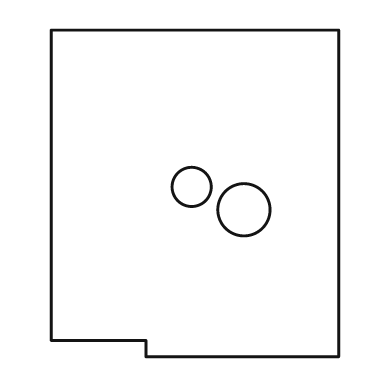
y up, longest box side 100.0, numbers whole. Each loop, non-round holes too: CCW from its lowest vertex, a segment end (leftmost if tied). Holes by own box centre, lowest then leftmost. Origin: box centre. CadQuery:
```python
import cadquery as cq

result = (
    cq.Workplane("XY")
    .moveTo(-15.0, -50.0)
    .lineTo(44.0, -50.0)
    .lineTo(44.0, 50.0)
    .lineTo(-44.0, 50.0)
    .lineTo(-44.0, -45.0)
    .lineTo(-15.0, -45.0)
    .close()
    .moveTo(15.0, -5.0)
    .circle(8.0)
    .moveTo(-1.0, 2.0)
    .circle(6.0)
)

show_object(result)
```